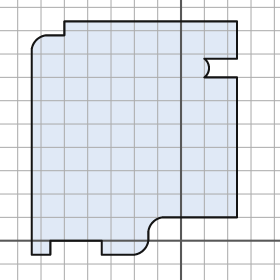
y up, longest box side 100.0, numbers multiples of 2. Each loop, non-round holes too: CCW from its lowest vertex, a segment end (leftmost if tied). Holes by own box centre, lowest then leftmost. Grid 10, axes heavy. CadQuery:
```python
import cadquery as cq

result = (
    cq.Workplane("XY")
    .moveTo(-64.0, -6.0)
    .lineTo(-56.0, -6.0)
    .lineTo(-56.0, 0.0)
    .lineTo(-34.0, 0.0)
    .lineTo(-34.0, -6.0)
    .lineTo(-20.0, -6.0)
    .threePointArc((-16.0, -4.0), (-14.0, 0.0))
    .lineTo(-14.0, 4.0)
    .threePointArc((-12.0, 8.0), (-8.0, 10.0))
    .lineTo(24.0, 10.0)
    .lineTo(24.0, 70.0)
    .lineTo(10.0, 70.0)
    .threePointArc((12.0, 74.0), (10.0, 78.0))
    .lineTo(24.0, 78.0)
    .lineTo(24.0, 94.0)
    .lineTo(-50.0, 94.0)
    .lineTo(-50.0, 88.0)
    .lineTo(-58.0, 88.0)
    .threePointArc((-62.0, 86.0), (-64.0, 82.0))
    .close()
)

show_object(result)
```